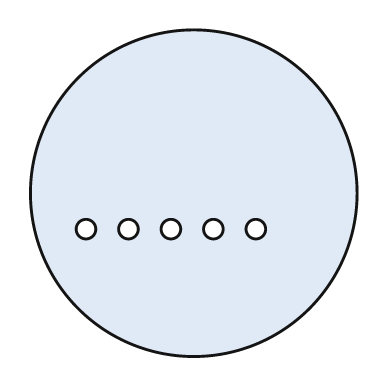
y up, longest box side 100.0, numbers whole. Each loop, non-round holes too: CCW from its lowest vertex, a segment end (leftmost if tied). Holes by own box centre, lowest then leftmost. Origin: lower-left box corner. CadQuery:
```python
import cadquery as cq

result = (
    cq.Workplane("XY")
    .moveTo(50.0, 50.0)
    .circle(50.0)
    .moveTo(17.0, 39.0)
    .circle(3.0)
    .moveTo(30.0, 39.0)
    .circle(3.0)
    .moveTo(43.0, 39.0)
    .circle(3.0)
    .moveTo(56.0, 39.0)
    .circle(3.0)
    .moveTo(69.0, 39.0)
    .circle(3.0)
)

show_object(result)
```